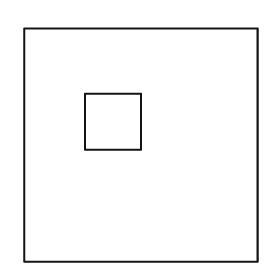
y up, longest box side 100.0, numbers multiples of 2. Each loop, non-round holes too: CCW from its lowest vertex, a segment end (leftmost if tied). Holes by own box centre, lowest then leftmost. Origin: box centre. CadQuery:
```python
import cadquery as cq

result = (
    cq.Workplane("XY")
    .moveTo(-50.0, -50.0)
    .lineTo(50.0, -50.0)
    .lineTo(50.0, 50.0)
    .lineTo(-50.0, 50.0)
    .close()
    .moveTo(-24.0, -2.0)
    .lineTo(0.0, -2.0)
    .lineTo(0.0, 22.0)
    .lineTo(-24.0, 22.0)
    .close()
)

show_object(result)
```